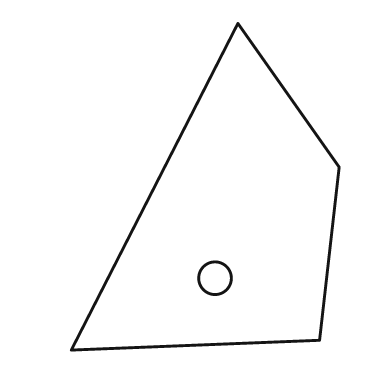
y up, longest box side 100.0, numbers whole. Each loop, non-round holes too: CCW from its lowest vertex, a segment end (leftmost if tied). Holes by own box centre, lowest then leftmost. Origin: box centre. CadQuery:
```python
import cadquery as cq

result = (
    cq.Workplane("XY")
    .moveTo(-41.0, -50.0)
    .lineTo(35.0, -47.0)
    .lineTo(41.0, 6.0)
    .lineTo(10.0, 50.0)
    .close()
    .moveTo(3.0, -28.0)
    .circle(5.0)
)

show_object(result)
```